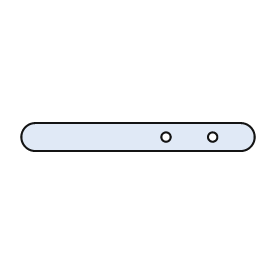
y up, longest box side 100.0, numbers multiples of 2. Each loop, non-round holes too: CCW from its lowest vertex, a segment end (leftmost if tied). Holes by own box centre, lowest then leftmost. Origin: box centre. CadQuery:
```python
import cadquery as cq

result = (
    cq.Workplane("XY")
    .moveTo(-44.0, -6.0)
    .lineTo(44.0, -6.0)
    .threePointArc((50.0, 0.0), (44.0, 6.0))
    .lineTo(-44.0, 6.0)
    .threePointArc((-50.0, 0.0), (-44.0, -6.0))
    .close()
    .moveTo(12.0, 0.0)
    .circle(2.0)
    .moveTo(32.0, 0.0)
    .circle(2.0)
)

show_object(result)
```